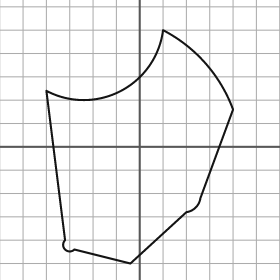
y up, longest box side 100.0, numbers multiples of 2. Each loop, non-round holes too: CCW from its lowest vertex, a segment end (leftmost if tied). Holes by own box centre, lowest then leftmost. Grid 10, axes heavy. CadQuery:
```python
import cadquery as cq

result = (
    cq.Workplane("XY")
    .moveTo(-4.0, -50.0)
    .lineTo(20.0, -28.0)
    .threePointArc((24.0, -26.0), (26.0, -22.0))
    .lineTo(40.0, 16.0)
    .threePointArc((28.0, 36.0), (10.0, 50.0))
    .threePointArc((-8.0, 24.0), (-40.0, 24.0))
    .lineTo(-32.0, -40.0)
    .threePointArc((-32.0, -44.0), (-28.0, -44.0))
    .close()
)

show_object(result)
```